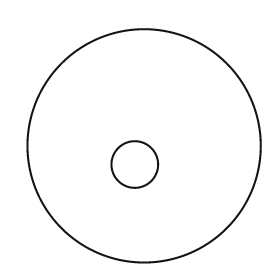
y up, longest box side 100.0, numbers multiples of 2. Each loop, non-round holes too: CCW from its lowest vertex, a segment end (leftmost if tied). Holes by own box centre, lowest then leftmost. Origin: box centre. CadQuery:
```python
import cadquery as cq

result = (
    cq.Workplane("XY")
    .moveTo(0.0, 0.0)
    .circle(50.0)
    .moveTo(-4.0, -8.0)
    .circle(10.0)
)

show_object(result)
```